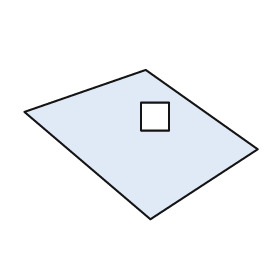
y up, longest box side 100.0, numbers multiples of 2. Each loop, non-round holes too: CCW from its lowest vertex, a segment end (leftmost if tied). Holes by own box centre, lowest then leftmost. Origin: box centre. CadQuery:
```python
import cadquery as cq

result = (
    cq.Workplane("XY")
    .moveTo(4.0, -32.0)
    .lineTo(50.0, -2.0)
    .lineTo(2.0, 32.0)
    .lineTo(-50.0, 14.0)
    .close()
    .moveTo(0.0, 6.0)
    .lineTo(12.0, 6.0)
    .lineTo(12.0, 18.0)
    .lineTo(0.0, 18.0)
    .close()
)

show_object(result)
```